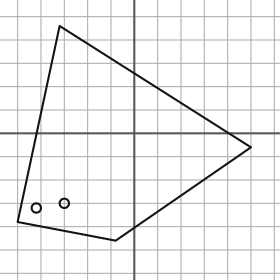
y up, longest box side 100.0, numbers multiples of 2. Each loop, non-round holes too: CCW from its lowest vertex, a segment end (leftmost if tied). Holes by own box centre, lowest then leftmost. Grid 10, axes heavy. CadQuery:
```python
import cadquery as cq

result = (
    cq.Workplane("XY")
    .moveTo(-8.0, -46.0)
    .lineTo(50.0, -6.0)
    .lineTo(-32.0, 46.0)
    .lineTo(-50.0, -38.0)
    .close()
    .moveTo(-42.0, -32.0)
    .circle(2.0)
    .moveTo(-30.0, -30.0)
    .circle(2.0)
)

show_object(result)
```